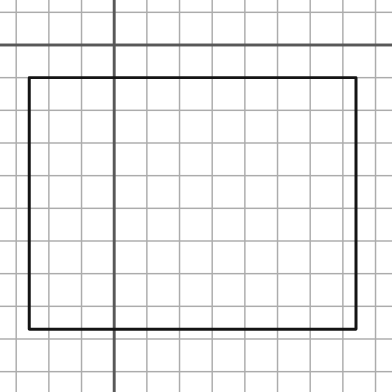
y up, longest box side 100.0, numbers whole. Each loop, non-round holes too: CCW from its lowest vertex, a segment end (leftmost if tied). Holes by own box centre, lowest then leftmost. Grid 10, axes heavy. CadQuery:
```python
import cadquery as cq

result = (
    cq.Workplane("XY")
    .moveTo(-26.0, -87.0)
    .lineTo(74.0, -87.0)
    .lineTo(74.0, -10.0)
    .lineTo(-26.0, -10.0)
    .close()
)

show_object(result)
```